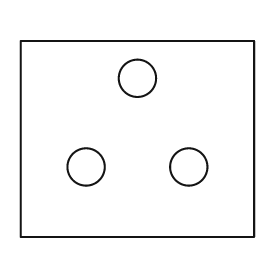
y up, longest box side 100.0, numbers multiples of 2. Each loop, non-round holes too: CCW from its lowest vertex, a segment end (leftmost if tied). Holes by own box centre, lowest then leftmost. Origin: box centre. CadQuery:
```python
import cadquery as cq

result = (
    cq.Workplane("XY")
    .moveTo(-50.0, -42.0)
    .lineTo(50.0, -42.0)
    .lineTo(50.0, 42.0)
    .lineTo(-50.0, 42.0)
    .close()
    .moveTo(-22.0, -12.0)
    .circle(8.0)
    .moveTo(22.0, -12.0)
    .circle(8.0)
    .moveTo(0.0, 26.0)
    .circle(8.0)
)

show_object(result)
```